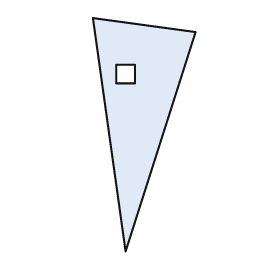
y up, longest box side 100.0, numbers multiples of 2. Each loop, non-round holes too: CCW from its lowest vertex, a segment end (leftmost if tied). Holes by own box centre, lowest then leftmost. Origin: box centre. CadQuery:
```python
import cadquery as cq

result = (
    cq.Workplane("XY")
    .moveTo(-8.0, -50.0)
    .lineTo(22.0, 44.0)
    .lineTo(-22.0, 50.0)
    .close()
    .moveTo(-12.0, 22.0)
    .lineTo(-4.0, 22.0)
    .lineTo(-4.0, 30.0)
    .lineTo(-12.0, 30.0)
    .close()
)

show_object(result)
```